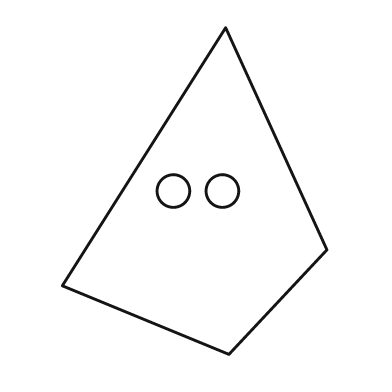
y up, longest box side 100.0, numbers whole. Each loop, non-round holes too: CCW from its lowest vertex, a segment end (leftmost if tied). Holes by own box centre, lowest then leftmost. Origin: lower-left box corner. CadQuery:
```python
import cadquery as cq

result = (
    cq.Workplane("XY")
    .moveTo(51.0, 0.0)
    .lineTo(81.0, 32.0)
    .lineTo(50.0, 100.0)
    .lineTo(0.0, 21.0)
    .close()
    .moveTo(34.0, 50.0)
    .circle(5.0)
    .moveTo(49.0, 50.0)
    .circle(5.0)
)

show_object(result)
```